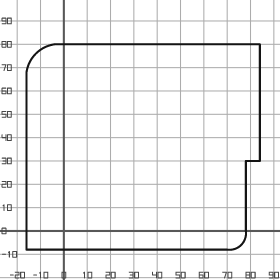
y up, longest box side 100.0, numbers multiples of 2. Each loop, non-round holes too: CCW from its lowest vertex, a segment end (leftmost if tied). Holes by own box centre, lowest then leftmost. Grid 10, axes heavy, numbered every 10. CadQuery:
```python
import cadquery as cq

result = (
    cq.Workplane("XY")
    .moveTo(-16.0, -8.0)
    .lineTo(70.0, -8.0)
    .threePointArc((76.0, -6.0), (78.0, 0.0))
    .lineTo(78.0, 30.0)
    .lineTo(84.0, 30.0)
    .lineTo(84.0, 80.0)
    .lineTo(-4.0, 80.0)
    .threePointArc((-12.0, 76.0), (-16.0, 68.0))
    .close()
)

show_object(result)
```